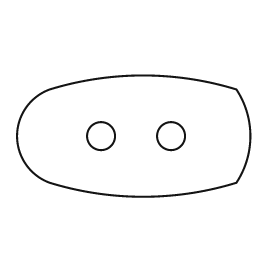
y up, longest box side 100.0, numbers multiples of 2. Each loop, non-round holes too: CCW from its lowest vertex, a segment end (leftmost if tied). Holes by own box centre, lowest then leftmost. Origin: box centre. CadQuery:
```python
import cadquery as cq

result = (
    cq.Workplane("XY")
    .moveTo(-36.0, -20.0)
    .threePointArc((4.0, -26.0), (44.0, -20.0))
    .threePointArc((50.0, 0.0), (44.0, 20.0))
    .threePointArc((4.0, 26.0), (-36.0, 20.0))
    .threePointArc((-50.0, 0.0), (-36.0, -20.0))
    .close()
    .moveTo(-14.0, 0.0)
    .circle(6.0)
    .moveTo(16.0, 0.0)
    .circle(6.0)
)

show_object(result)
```